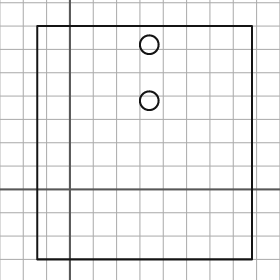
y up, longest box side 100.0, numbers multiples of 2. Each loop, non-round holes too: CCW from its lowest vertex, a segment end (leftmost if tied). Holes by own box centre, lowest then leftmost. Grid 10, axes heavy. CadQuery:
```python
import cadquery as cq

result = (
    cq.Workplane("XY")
    .moveTo(-14.0, -30.0)
    .lineTo(78.0, -30.0)
    .lineTo(78.0, 70.0)
    .lineTo(-14.0, 70.0)
    .close()
    .moveTo(34.0, 38.0)
    .circle(4.0)
    .moveTo(34.0, 62.0)
    .circle(4.0)
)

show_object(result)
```